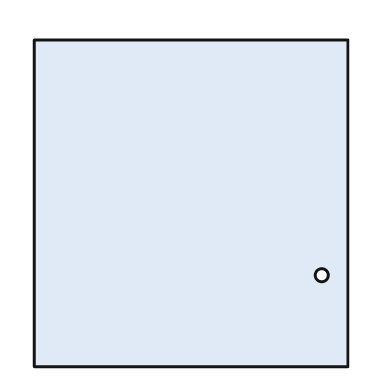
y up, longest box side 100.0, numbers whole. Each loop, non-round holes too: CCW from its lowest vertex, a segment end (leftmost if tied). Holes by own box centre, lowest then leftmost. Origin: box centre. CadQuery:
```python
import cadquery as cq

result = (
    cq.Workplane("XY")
    .moveTo(-48.0, -50.0)
    .lineTo(48.0, -50.0)
    .lineTo(48.0, 50.0)
    .lineTo(-48.0, 50.0)
    .close()
    .moveTo(40.0, -22.0)
    .circle(2.0)
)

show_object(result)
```